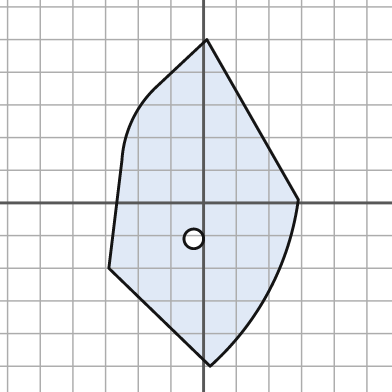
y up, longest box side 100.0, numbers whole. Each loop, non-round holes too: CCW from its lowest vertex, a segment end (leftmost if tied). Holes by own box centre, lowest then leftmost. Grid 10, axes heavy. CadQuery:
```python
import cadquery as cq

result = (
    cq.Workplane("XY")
    .moveTo(2.0, -50.0)
    .threePointArc((20.0, -27.0), (29.0, 1.0))
    .lineTo(1.0, 50.0)
    .lineTo(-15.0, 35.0)
    .threePointArc((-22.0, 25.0), (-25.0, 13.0))
    .lineTo(-29.0, -20.0)
    .close()
    .moveTo(-3.0, -11.0)
    .circle(3.0)
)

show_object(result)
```